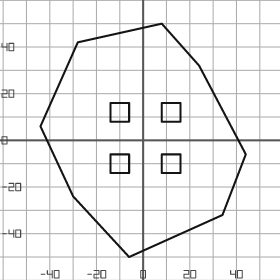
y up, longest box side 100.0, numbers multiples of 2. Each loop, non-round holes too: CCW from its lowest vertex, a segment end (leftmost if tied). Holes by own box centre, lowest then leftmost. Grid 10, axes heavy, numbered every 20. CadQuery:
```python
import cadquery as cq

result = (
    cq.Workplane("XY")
    .moveTo(-6.0, -50.0)
    .lineTo(34.0, -32.0)
    .lineTo(44.0, -6.0)
    .lineTo(24.0, 32.0)
    .lineTo(8.0, 50.0)
    .lineTo(-28.0, 42.0)
    .lineTo(-44.0, 6.0)
    .lineTo(-30.0, -24.0)
    .close()
    .moveTo(-14.0, -14.0)
    .lineTo(-6.0, -14.0)
    .lineTo(-6.0, -6.0)
    .lineTo(-14.0, -6.0)
    .close()
    .moveTo(8.0, -14.0)
    .lineTo(16.0, -14.0)
    .lineTo(16.0, -6.0)
    .lineTo(8.0, -6.0)
    .close()
    .moveTo(-14.0, 8.0)
    .lineTo(-6.0, 8.0)
    .lineTo(-6.0, 16.0)
    .lineTo(-14.0, 16.0)
    .close()
    .moveTo(8.0, 8.0)
    .lineTo(16.0, 8.0)
    .lineTo(16.0, 16.0)
    .lineTo(8.0, 16.0)
    .close()
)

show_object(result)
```